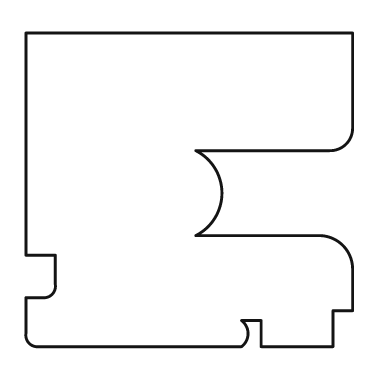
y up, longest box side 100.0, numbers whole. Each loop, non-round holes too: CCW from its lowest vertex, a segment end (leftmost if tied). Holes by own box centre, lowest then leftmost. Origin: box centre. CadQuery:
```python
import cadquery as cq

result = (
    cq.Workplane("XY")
    .moveTo(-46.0, -48.0)
    .lineTo(16.0, -48.0)
    .threePointArc((18.0, -44.0), (16.0, -40.0))
    .lineTo(22.0, -40.0)
    .lineTo(22.0, -48.0)
    .lineTo(44.0, -48.0)
    .lineTo(44.0, -37.0)
    .lineTo(50.0, -37.0)
    .lineTo(50.0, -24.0)
    .threePointArc((47.0, -17.0), (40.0, -14.0))
    .lineTo(2.0, -14.0)
    .threePointArc((10.0, -1.0), (2.0, 12.0))
    .lineTo(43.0, 12.0)
    .threePointArc((48.0, 14.0), (50.0, 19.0))
    .lineTo(50.0, 48.0)
    .lineTo(-50.0, 48.0)
    .lineTo(-50.0, -20.0)
    .lineTo(-41.0, -20.0)
    .lineTo(-41.0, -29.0)
    .threePointArc((-42.0, -32.0), (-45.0, -33.0))
    .lineTo(-50.0, -33.0)
    .lineTo(-50.0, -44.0)
    .threePointArc((-49.0, -47.0), (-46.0, -48.0))
    .close()
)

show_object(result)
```